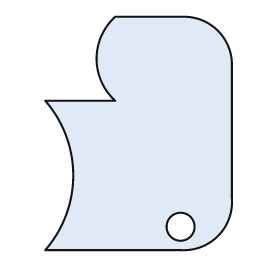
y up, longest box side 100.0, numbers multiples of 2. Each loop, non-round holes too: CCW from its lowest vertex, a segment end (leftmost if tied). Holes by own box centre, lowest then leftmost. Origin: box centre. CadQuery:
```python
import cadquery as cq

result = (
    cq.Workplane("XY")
    .moveTo(-40.0, -50.0)
    .lineTo(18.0, -50.0)
    .threePointArc((34.0, -44.0), (40.0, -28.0))
    .lineTo(40.0, 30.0)
    .threePointArc((34.0, 44.0), (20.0, 50.0))
    .lineTo(-10.0, 50.0)
    .threePointArc((-18.0, 32.0), (-10.0, 14.0))
    .lineTo(-40.0, 14.0)
    .threePointArc((-28.0, -18.0), (-40.0, -50.0))
    .close()
    .moveTo(18.0, -40.0)
    .circle(6.0)
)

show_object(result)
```